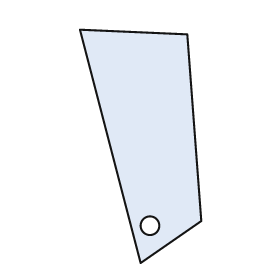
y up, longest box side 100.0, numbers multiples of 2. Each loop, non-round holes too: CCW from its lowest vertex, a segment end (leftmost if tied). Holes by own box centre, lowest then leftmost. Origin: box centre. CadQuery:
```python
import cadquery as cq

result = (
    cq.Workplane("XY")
    .moveTo(0.0, -50.0)
    .lineTo(26.0, -32.0)
    .lineTo(20.0, 48.0)
    .lineTo(-26.0, 50.0)
    .close()
    .moveTo(4.0, -34.0)
    .circle(4.0)
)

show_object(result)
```